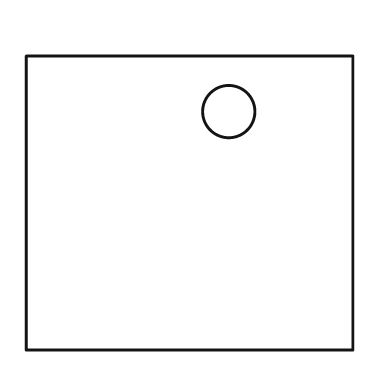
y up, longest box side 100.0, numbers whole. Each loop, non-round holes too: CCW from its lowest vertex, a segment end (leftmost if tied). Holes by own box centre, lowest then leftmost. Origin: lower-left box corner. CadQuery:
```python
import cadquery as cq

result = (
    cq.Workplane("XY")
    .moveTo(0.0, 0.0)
    .lineTo(100.0, 0.0)
    .lineTo(100.0, 90.0)
    .lineTo(0.0, 90.0)
    .close()
    .moveTo(62.0, 73.0)
    .circle(8.0)
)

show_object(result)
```